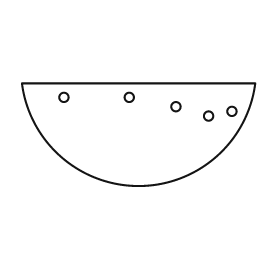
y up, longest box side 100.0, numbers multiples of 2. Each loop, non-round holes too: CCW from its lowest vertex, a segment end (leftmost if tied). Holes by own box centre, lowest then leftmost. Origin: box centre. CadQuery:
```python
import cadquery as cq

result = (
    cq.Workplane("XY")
    .moveTo(-50.0, 22.0)
    .threePointArc((0.0, -22.0), (50.0, 22.0))
    .close()
    .moveTo(30.0, 8.0)
    .circle(2.0)
    .moveTo(40.0, 10.0)
    .circle(2.0)
    .moveTo(16.0, 12.0)
    .circle(2.0)
    .moveTo(-32.0, 16.0)
    .circle(2.0)
    .moveTo(-4.0, 16.0)
    .circle(2.0)
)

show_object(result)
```